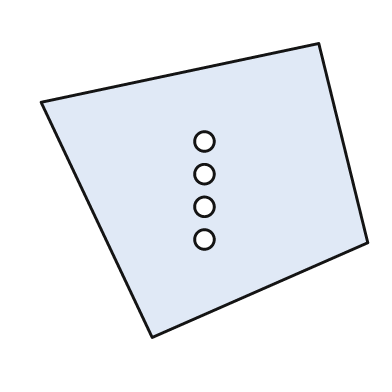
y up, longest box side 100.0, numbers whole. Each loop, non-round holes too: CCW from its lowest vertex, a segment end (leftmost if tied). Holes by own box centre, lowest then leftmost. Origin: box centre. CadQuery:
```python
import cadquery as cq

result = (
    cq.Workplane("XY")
    .moveTo(-16.0, -45.0)
    .lineTo(50.0, -16.0)
    .lineTo(35.0, 45.0)
    .lineTo(-50.0, 27.0)
    .close()
    .moveTo(0.0, -15.0)
    .circle(3.0)
    .moveTo(0.0, -5.0)
    .circle(3.0)
    .moveTo(0.0, 5.0)
    .circle(3.0)
    .moveTo(0.0, 15.0)
    .circle(3.0)
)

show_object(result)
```